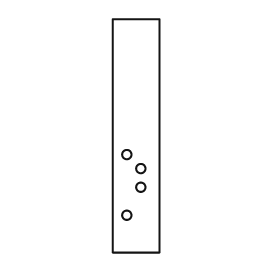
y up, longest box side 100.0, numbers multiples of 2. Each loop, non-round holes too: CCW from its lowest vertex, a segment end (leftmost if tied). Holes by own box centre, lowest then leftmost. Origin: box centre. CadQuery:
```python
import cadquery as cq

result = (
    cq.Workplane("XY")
    .moveTo(-10.0, -50.0)
    .lineTo(10.0, -50.0)
    .lineTo(10.0, 50.0)
    .lineTo(-10.0, 50.0)
    .close()
    .moveTo(-4.0, -34.0)
    .circle(2.0)
    .moveTo(2.0, -22.0)
    .circle(2.0)
    .moveTo(2.0, -14.0)
    .circle(2.0)
    .moveTo(-4.0, -8.0)
    .circle(2.0)
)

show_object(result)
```